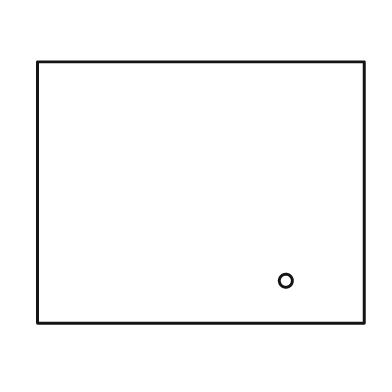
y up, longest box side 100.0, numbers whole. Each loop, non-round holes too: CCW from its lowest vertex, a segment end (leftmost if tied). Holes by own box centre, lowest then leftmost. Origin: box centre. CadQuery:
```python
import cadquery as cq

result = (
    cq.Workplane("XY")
    .moveTo(-50.0, -40.0)
    .lineTo(50.0, -40.0)
    .lineTo(50.0, 40.0)
    .lineTo(-50.0, 40.0)
    .close()
    .moveTo(26.0, -27.0)
    .circle(2.0)
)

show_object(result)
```